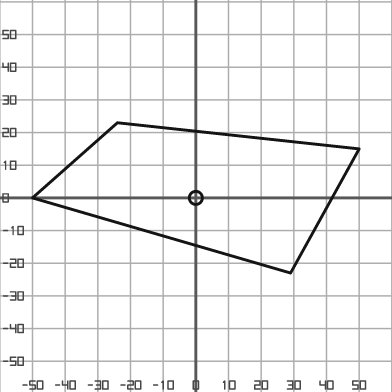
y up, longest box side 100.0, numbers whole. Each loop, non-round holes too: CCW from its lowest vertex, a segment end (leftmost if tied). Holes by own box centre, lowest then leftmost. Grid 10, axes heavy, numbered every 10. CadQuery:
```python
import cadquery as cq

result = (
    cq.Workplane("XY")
    .moveTo(29.0, -23.0)
    .lineTo(50.0, 15.0)
    .lineTo(-24.0, 23.0)
    .lineTo(-50.0, 0.0)
    .close()
    .moveTo(0.0, 0.0)
    .circle(2.0)
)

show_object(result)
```